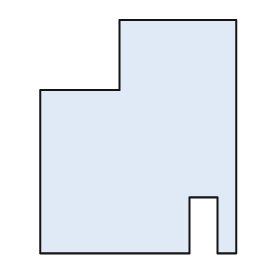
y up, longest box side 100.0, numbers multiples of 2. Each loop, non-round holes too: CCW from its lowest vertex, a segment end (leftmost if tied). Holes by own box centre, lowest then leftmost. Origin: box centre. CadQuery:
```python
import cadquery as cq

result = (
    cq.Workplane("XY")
    .moveTo(-42.0, -50.0)
    .lineTo(22.0, -50.0)
    .lineTo(22.0, -26.0)
    .lineTo(34.0, -26.0)
    .lineTo(34.0, -50.0)
    .lineTo(42.0, -50.0)
    .lineTo(42.0, 50.0)
    .lineTo(-8.0, 50.0)
    .lineTo(-8.0, 20.0)
    .lineTo(-42.0, 20.0)
    .close()
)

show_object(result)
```